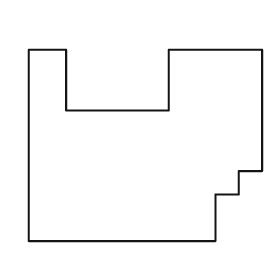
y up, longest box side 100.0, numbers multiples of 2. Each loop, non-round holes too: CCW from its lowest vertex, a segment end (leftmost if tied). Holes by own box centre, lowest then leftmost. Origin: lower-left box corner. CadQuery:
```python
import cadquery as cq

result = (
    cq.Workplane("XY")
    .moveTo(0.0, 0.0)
    .lineTo(80.0, 0.0)
    .lineTo(80.0, 20.0)
    .lineTo(90.0, 20.0)
    .lineTo(90.0, 30.0)
    .lineTo(100.0, 30.0)
    .lineTo(100.0, 82.0)
    .lineTo(60.0, 82.0)
    .lineTo(60.0, 56.0)
    .lineTo(16.0, 56.0)
    .lineTo(16.0, 82.0)
    .lineTo(0.0, 82.0)
    .close()
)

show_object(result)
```